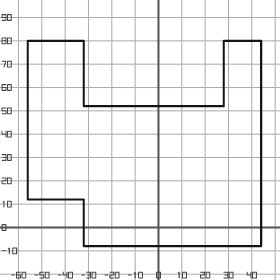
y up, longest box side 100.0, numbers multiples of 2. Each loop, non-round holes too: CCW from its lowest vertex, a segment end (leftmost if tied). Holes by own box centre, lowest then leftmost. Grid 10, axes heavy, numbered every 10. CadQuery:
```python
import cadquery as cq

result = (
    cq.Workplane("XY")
    .moveTo(-32.0, -8.0)
    .lineTo(44.0, -8.0)
    .lineTo(44.0, 80.0)
    .lineTo(28.0, 80.0)
    .lineTo(28.0, 52.0)
    .lineTo(-32.0, 52.0)
    .lineTo(-32.0, 80.0)
    .lineTo(-56.0, 80.0)
    .lineTo(-56.0, 12.0)
    .lineTo(-32.0, 12.0)
    .close()
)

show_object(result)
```